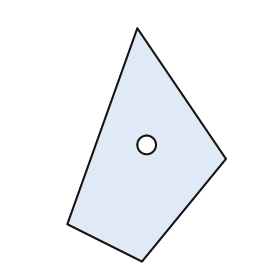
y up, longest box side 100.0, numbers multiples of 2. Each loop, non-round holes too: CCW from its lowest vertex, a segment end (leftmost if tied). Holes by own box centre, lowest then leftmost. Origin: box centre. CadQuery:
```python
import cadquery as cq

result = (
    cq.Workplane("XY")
    .moveTo(-2.0, -50.0)
    .lineTo(34.0, -6.0)
    .lineTo(-4.0, 50.0)
    .lineTo(-34.0, -34.0)
    .close()
    .moveTo(0.0, 0.0)
    .circle(4.0)
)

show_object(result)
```